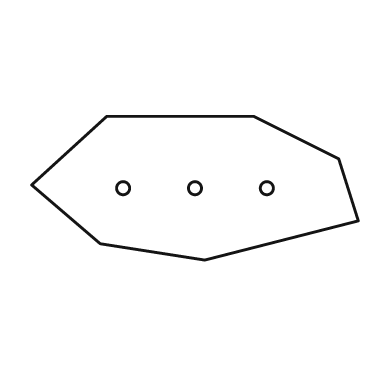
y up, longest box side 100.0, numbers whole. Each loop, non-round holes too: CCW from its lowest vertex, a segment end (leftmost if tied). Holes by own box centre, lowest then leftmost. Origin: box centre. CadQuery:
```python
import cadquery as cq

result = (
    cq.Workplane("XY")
    .moveTo(3.0, -22.0)
    .lineTo(50.0, -10.0)
    .lineTo(44.0, 9.0)
    .lineTo(18.0, 22.0)
    .lineTo(-27.0, 22.0)
    .lineTo(-50.0, 1.0)
    .lineTo(-29.0, -17.0)
    .close()
    .moveTo(-22.0, 0.0)
    .circle(2.0)
    .moveTo(0.0, 0.0)
    .circle(2.0)
    .moveTo(22.0, 0.0)
    .circle(2.0)
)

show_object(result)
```